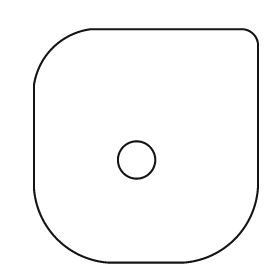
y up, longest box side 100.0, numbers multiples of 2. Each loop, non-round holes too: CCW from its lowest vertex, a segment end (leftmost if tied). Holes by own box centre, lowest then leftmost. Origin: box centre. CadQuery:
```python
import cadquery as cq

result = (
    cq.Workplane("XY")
    .moveTo(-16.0, -50.0)
    .lineTo(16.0, -50.0)
    .threePointArc((38.0, -40.0), (48.0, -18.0))
    .lineTo(48.0, 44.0)
    .threePointArc((46.0, 48.0), (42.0, 50.0))
    .lineTo(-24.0, 50.0)
    .threePointArc((-40.0, 42.0), (-48.0, 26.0))
    .lineTo(-48.0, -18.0)
    .threePointArc((-38.0, -40.0), (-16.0, -50.0))
    .close()
    .moveTo(-4.0, -6.0)
    .circle(8.0)
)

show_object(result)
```